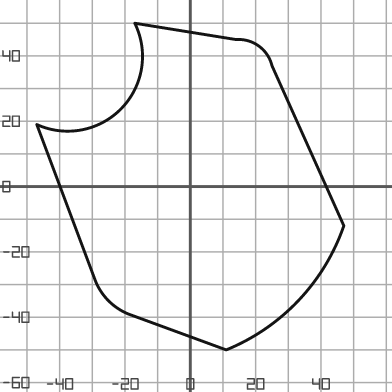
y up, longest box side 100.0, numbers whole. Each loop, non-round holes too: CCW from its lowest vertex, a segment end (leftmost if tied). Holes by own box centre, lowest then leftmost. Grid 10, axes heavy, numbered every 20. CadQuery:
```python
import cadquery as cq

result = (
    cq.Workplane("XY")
    .moveTo(11.0, -50.0)
    .threePointArc((33.0, -35.0), (47.0, -12.0))
    .lineTo(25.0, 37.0)
    .threePointArc((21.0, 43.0), (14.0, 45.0))
    .lineTo(-17.0, 50.0)
    .threePointArc((-21.0, 24.0), (-47.0, 19.0))
    .lineTo(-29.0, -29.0)
    .threePointArc((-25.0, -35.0), (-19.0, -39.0))
    .close()
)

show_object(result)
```